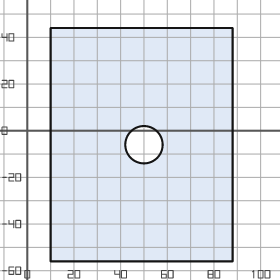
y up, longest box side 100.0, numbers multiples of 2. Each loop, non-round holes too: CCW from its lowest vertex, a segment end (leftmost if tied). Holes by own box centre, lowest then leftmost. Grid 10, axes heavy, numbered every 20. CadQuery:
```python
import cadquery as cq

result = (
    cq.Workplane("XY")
    .moveTo(10.0, -56.0)
    .lineTo(88.0, -56.0)
    .lineTo(88.0, 44.0)
    .lineTo(10.0, 44.0)
    .close()
    .moveTo(50.0, -6.0)
    .circle(8.0)
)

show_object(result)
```